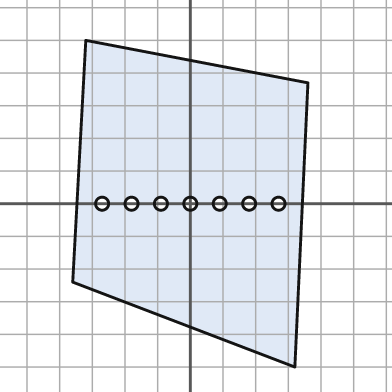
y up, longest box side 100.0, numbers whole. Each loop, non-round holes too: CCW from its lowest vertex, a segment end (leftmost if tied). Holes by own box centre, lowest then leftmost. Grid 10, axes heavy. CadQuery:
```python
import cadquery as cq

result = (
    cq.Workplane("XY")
    .moveTo(32.0, -50.0)
    .lineTo(36.0, 37.0)
    .lineTo(-32.0, 50.0)
    .lineTo(-36.0, -24.0)
    .close()
    .moveTo(-27.0, 0.0)
    .circle(2.0)
    .moveTo(-18.0, 0.0)
    .circle(2.0)
    .moveTo(-9.0, 0.0)
    .circle(2.0)
    .moveTo(0.0, 0.0)
    .circle(2.0)
    .moveTo(9.0, 0.0)
    .circle(2.0)
    .moveTo(18.0, 0.0)
    .circle(2.0)
    .moveTo(27.0, 0.0)
    .circle(2.0)
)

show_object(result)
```